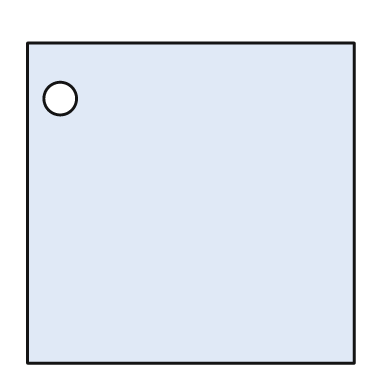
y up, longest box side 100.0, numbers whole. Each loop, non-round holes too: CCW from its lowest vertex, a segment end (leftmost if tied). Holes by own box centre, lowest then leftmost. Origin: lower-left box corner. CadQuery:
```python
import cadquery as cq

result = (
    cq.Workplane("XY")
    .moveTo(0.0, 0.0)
    .lineTo(100.0, 0.0)
    .lineTo(100.0, 98.0)
    .lineTo(0.0, 98.0)
    .close()
    .moveTo(10.0, 81.0)
    .circle(5.0)
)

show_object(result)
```